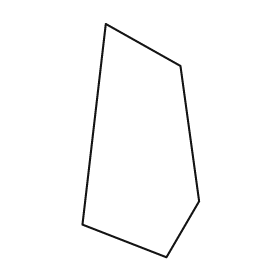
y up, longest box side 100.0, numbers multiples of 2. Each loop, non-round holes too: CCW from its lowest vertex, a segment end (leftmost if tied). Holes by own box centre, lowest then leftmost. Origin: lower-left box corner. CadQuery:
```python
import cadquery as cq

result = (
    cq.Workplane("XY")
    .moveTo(36.0, 0.0)
    .lineTo(50.0, 24.0)
    .lineTo(42.0, 82.0)
    .lineTo(10.0, 100.0)
    .lineTo(0.0, 14.0)
    .close()
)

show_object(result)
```